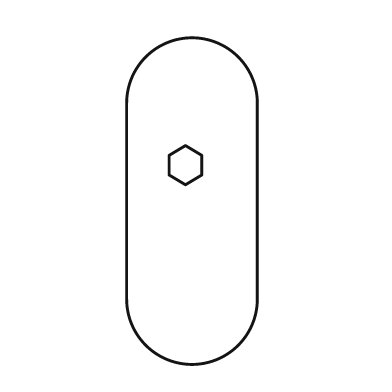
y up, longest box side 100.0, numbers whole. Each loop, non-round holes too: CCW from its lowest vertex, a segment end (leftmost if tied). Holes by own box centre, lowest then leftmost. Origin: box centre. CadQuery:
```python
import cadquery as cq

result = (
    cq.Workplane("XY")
    .moveTo(-20.0, -30.0)
    .threePointArc((0.0, -50.0), (20.0, -30.0))
    .lineTo(20.0, 30.0)
    .threePointArc((0.0, 50.0), (-20.0, 30.0))
    .close()
    .moveTo(-2.0, 5.0)
    .lineTo(3.0, 8.0)
    .lineTo(3.0, 14.0)
    .lineTo(-2.0, 17.0)
    .lineTo(-7.0, 14.0)
    .lineTo(-7.0, 8.0)
    .close()
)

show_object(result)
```